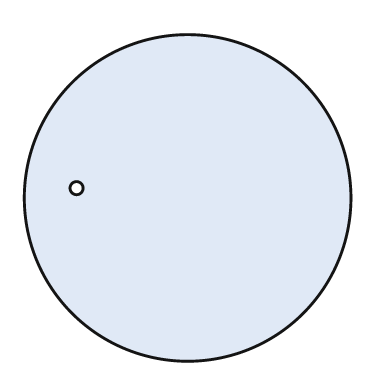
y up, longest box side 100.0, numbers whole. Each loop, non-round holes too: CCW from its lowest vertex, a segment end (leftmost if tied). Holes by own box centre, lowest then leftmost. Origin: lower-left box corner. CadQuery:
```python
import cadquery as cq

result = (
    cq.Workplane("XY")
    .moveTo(50.0, 50.0)
    .circle(50.0)
    .moveTo(16.0, 53.0)
    .circle(2.0)
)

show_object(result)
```